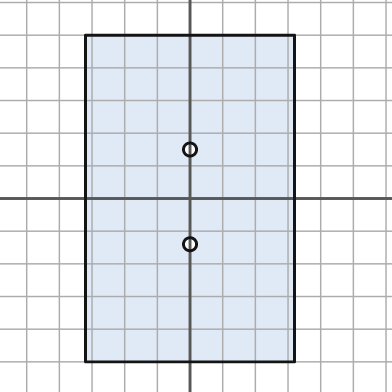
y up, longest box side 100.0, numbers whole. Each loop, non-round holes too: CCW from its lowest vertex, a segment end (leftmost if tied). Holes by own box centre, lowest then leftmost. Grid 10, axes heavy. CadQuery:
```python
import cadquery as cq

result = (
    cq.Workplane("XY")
    .moveTo(-32.0, -50.0)
    .lineTo(32.0, -50.0)
    .lineTo(32.0, 50.0)
    .lineTo(-32.0, 50.0)
    .close()
    .moveTo(0.0, -14.0)
    .circle(2.0)
    .moveTo(0.0, 15.0)
    .circle(2.0)
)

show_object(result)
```